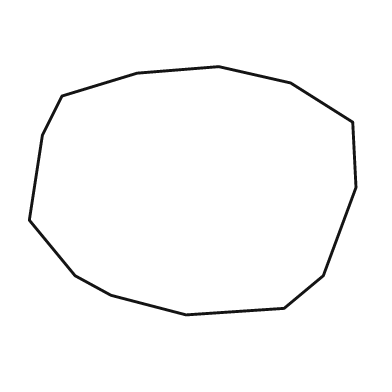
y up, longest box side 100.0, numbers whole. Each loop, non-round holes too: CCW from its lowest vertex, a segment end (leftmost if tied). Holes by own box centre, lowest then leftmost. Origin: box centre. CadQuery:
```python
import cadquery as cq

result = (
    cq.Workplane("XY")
    .moveTo(-2.0, -38.0)
    .lineTo(28.0, -36.0)
    .lineTo(40.0, -26.0)
    .lineTo(50.0, 1.0)
    .lineTo(49.0, 21.0)
    .lineTo(30.0, 33.0)
    .lineTo(8.0, 38.0)
    .lineTo(-17.0, 36.0)
    .lineTo(-40.0, 29.0)
    .lineTo(-46.0, 17.0)
    .lineTo(-50.0, -9.0)
    .lineTo(-36.0, -26.0)
    .lineTo(-25.0, -32.0)
    .close()
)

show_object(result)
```